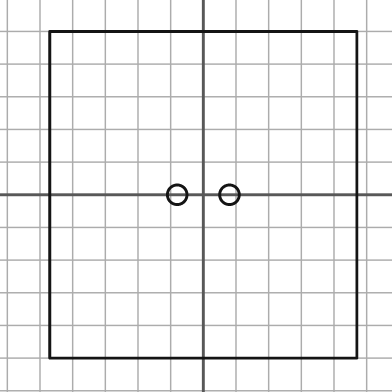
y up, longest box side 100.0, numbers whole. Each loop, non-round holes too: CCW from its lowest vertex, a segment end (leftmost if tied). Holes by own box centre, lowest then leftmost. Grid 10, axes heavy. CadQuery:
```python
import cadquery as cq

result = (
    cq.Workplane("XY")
    .moveTo(-47.0, -50.0)
    .lineTo(47.0, -50.0)
    .lineTo(47.0, 50.0)
    .lineTo(-47.0, 50.0)
    .close()
    .moveTo(-8.0, 0.0)
    .circle(3.0)
    .moveTo(8.0, 0.0)
    .circle(3.0)
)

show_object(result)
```